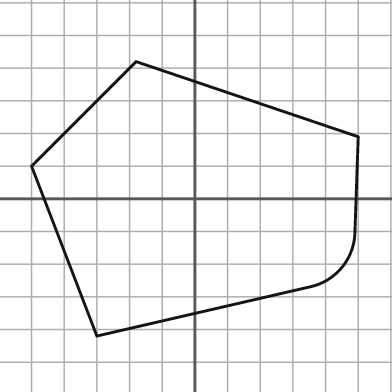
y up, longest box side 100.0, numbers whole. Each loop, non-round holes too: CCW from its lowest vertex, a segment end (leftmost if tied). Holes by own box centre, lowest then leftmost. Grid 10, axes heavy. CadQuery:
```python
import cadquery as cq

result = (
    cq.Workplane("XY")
    .moveTo(-30.0, -42.0)
    .lineTo(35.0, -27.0)
    .threePointArc((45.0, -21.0), (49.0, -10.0))
    .lineTo(50.0, 19.0)
    .lineTo(-18.0, 42.0)
    .lineTo(-50.0, 10.0)
    .close()
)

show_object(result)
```